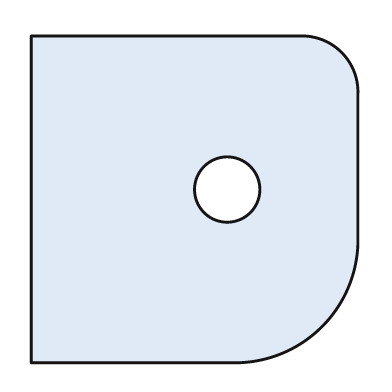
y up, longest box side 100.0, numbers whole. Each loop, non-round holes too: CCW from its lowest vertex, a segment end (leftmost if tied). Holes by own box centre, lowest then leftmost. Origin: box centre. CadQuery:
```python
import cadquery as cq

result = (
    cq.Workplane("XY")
    .moveTo(-50.0, -50.0)
    .lineTo(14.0, -50.0)
    .threePointArc((39.0, -39.0), (50.0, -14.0))
    .lineTo(50.0, 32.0)
    .threePointArc((45.0, 45.0), (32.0, 50.0))
    .lineTo(-50.0, 50.0)
    .close()
    .moveTo(10.0, 3.0)
    .circle(10.0)
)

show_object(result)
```